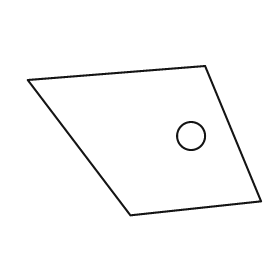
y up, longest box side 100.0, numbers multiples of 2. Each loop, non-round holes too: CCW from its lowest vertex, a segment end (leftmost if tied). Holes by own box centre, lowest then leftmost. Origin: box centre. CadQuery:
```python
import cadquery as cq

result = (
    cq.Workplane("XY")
    .moveTo(-6.0, -32.0)
    .lineTo(50.0, -26.0)
    .lineTo(26.0, 32.0)
    .lineTo(-50.0, 26.0)
    .close()
    .moveTo(20.0, 2.0)
    .circle(6.0)
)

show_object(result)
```